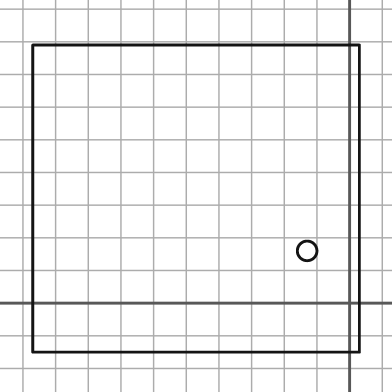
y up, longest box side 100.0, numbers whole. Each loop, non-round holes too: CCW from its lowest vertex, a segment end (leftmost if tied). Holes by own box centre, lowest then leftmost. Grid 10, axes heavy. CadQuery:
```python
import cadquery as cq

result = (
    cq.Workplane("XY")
    .moveTo(-97.0, -15.0)
    .lineTo(3.0, -15.0)
    .lineTo(3.0, 79.0)
    .lineTo(-97.0, 79.0)
    .close()
    .moveTo(-13.0, 16.0)
    .circle(3.0)
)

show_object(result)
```